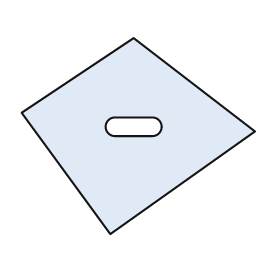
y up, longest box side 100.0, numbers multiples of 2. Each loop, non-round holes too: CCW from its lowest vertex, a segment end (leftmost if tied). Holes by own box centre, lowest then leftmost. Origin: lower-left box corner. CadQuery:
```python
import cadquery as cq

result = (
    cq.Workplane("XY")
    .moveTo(38.0, 0.0)
    .lineTo(100.0, 44.0)
    .lineTo(48.0, 84.0)
    .lineTo(0.0, 52.0)
    .close()
    .moveTo(40.0, 42.0)
    .lineTo(56.0, 42.0)
    .threePointArc((60.0, 46.0), (56.0, 50.0))
    .lineTo(40.0, 50.0)
    .threePointArc((36.0, 46.0), (40.0, 42.0))
    .close()
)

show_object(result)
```